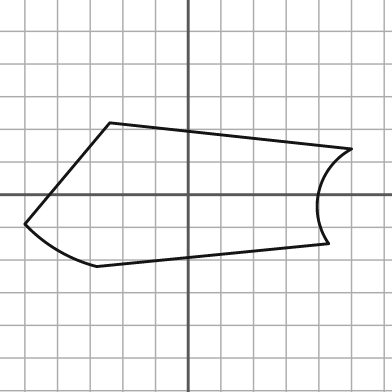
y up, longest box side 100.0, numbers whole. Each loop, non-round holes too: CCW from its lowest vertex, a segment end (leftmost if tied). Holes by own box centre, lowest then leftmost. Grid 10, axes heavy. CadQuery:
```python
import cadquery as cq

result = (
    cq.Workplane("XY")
    .moveTo(-28.0, -22.0)
    .lineTo(43.0, -15.0)
    .threePointArc((40.0, 1.0), (50.0, 14.0))
    .lineTo(-24.0, 22.0)
    .lineTo(-50.0, -9.0)
    .threePointArc((-40.0, -17.0), (-28.0, -22.0))
    .close()
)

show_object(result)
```